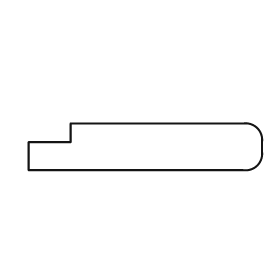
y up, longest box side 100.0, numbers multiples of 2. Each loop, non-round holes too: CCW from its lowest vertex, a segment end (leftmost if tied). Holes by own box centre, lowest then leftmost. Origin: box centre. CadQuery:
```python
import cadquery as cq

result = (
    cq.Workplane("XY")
    .moveTo(-50.0, -10.0)
    .lineTo(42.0, -10.0)
    .threePointArc((48.0, -8.0), (50.0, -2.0))
    .lineTo(50.0, 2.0)
    .threePointArc((48.0, 8.0), (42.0, 10.0))
    .lineTo(-32.0, 10.0)
    .lineTo(-32.0, 2.0)
    .lineTo(-50.0, 2.0)
    .close()
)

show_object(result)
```